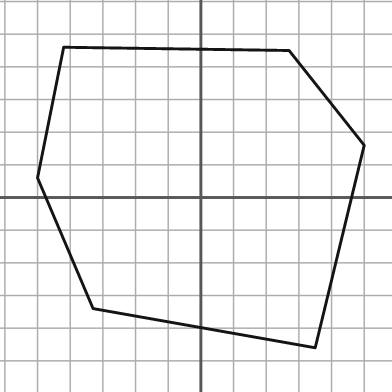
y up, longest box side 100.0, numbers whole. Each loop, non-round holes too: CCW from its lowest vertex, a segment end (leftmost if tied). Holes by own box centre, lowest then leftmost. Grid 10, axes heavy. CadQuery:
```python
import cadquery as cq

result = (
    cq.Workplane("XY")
    .moveTo(35.0, -46.0)
    .lineTo(50.0, 16.0)
    .lineTo(27.0, 45.0)
    .lineTo(-42.0, 46.0)
    .lineTo(-50.0, 6.0)
    .lineTo(-33.0, -34.0)
    .close()
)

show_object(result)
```